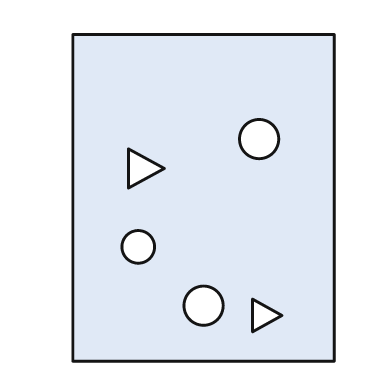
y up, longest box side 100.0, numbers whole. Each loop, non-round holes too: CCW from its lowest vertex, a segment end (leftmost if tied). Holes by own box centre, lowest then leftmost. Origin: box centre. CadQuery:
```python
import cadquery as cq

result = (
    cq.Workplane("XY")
    .moveTo(-40.0, -50.0)
    .lineTo(40.0, -50.0)
    .lineTo(40.0, 50.0)
    .lineTo(-40.0, 50.0)
    .close()
    .moveTo(15.0, -41.0)
    .lineTo(24.0, -36.0)
    .lineTo(15.0, -31.0)
    .close()
    .moveTo(0.0, -33.0)
    .circle(6.0)
    .moveTo(-20.0, -15.0)
    .circle(5.0)
    .moveTo(-23.0, 3.0)
    .lineTo(-12.0, 9.0)
    .lineTo(-23.0, 15.0)
    .close()
    .moveTo(17.0, 18.0)
    .circle(6.0)
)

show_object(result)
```